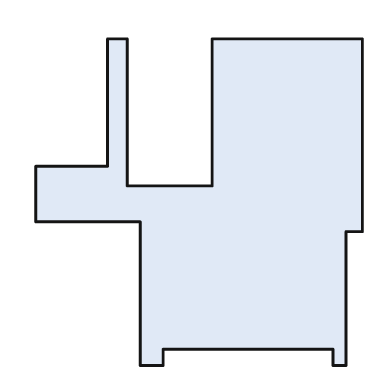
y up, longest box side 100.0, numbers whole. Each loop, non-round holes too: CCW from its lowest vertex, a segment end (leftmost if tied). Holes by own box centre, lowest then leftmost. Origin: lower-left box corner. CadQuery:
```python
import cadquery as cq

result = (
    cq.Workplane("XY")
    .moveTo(32.0, 0.0)
    .lineTo(39.0, 0.0)
    .lineTo(39.0, 5.0)
    .lineTo(91.0, 5.0)
    .lineTo(91.0, 0.0)
    .lineTo(95.0, 0.0)
    .lineTo(95.0, 41.0)
    .lineTo(100.0, 41.0)
    .lineTo(100.0, 100.0)
    .lineTo(54.0, 100.0)
    .lineTo(54.0, 55.0)
    .lineTo(28.0, 55.0)
    .lineTo(28.0, 100.0)
    .lineTo(22.0, 100.0)
    .lineTo(22.0, 61.0)
    .lineTo(0.0, 61.0)
    .lineTo(0.0, 44.0)
    .lineTo(32.0, 44.0)
    .close()
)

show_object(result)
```